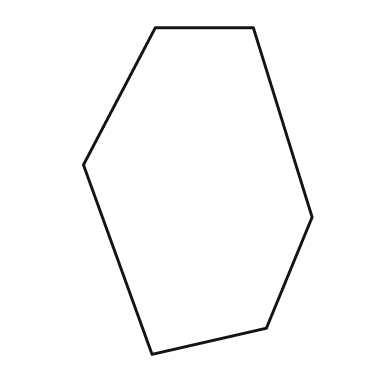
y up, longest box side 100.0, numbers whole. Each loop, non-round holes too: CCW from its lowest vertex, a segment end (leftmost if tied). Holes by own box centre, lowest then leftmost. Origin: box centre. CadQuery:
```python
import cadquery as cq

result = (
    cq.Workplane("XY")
    .moveTo(-14.0, -50.0)
    .lineTo(21.0, -42.0)
    .lineTo(35.0, -8.0)
    .lineTo(17.0, 50.0)
    .lineTo(-13.0, 50.0)
    .lineTo(-35.0, 8.0)
    .close()
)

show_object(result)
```